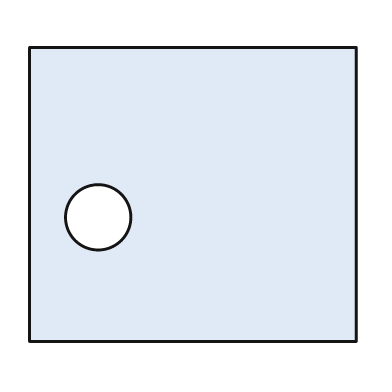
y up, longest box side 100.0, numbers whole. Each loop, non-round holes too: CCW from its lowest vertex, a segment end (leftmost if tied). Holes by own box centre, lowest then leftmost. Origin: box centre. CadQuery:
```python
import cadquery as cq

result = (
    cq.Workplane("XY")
    .moveTo(-50.0, -45.0)
    .lineTo(50.0, -45.0)
    .lineTo(50.0, 45.0)
    .lineTo(-50.0, 45.0)
    .close()
    .moveTo(-29.0, -7.0)
    .circle(10.0)
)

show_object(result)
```